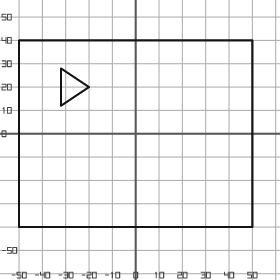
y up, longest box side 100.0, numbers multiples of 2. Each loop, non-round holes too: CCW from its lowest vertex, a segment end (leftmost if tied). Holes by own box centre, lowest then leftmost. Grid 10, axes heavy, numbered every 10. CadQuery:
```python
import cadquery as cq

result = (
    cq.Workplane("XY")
    .moveTo(-50.0, -40.0)
    .lineTo(50.0, -40.0)
    .lineTo(50.0, 40.0)
    .lineTo(-50.0, 40.0)
    .close()
    .moveTo(-32.0, 12.0)
    .lineTo(-20.0, 20.0)
    .lineTo(-32.0, 28.0)
    .close()
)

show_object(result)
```